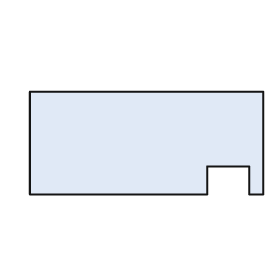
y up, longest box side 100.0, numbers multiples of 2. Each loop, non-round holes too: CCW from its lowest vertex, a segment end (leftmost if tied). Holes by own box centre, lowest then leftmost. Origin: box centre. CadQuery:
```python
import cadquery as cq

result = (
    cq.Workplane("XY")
    .moveTo(-50.0, -22.0)
    .lineTo(26.0, -22.0)
    .lineTo(26.0, -10.0)
    .lineTo(44.0, -10.0)
    .lineTo(44.0, -22.0)
    .lineTo(50.0, -22.0)
    .lineTo(50.0, 22.0)
    .lineTo(-50.0, 22.0)
    .close()
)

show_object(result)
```